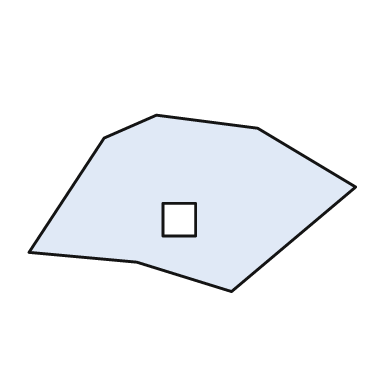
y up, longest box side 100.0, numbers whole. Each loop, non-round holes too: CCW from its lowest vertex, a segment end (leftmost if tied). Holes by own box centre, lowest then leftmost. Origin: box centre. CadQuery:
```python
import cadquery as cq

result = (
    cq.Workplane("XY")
    .moveTo(12.0, -27.0)
    .lineTo(50.0, 5.0)
    .lineTo(20.0, 23.0)
    .lineTo(-11.0, 27.0)
    .lineTo(-27.0, 20.0)
    .lineTo(-50.0, -15.0)
    .lineTo(-17.0, -18.0)
    .close()
    .moveTo(-9.0, -10.0)
    .lineTo(1.0, -10.0)
    .lineTo(1.0, 0.0)
    .lineTo(-9.0, 0.0)
    .close()
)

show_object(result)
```